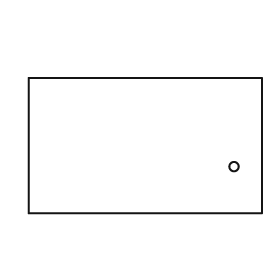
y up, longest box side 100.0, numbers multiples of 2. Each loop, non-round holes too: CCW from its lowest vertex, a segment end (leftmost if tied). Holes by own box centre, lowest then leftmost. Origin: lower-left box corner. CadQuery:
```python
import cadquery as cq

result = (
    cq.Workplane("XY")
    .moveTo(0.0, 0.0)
    .lineTo(100.0, 0.0)
    .lineTo(100.0, 58.0)
    .lineTo(0.0, 58.0)
    .close()
    .moveTo(88.0, 20.0)
    .circle(2.0)
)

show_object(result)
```